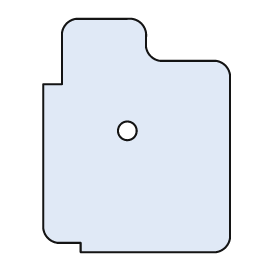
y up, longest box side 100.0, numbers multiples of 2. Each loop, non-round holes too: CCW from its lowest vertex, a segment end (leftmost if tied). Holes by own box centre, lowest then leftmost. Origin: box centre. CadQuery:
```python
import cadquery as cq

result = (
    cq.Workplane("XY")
    .moveTo(-24.0, -50.0)
    .lineTo(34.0, -50.0)
    .threePointArc((38.0, -48.0), (40.0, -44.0))
    .lineTo(40.0, 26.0)
    .threePointArc((38.0, 30.0), (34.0, 32.0))
    .lineTo(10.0, 32.0)
    .threePointArc((6.0, 34.0), (4.0, 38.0))
    .lineTo(4.0, 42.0)
    .threePointArc((2.0, 48.0), (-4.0, 50.0))
    .lineTo(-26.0, 50.0)
    .threePointArc((-30.0, 48.0), (-32.0, 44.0))
    .lineTo(-32.0, 22.0)
    .lineTo(-40.0, 22.0)
    .lineTo(-40.0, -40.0)
    .threePointArc((-38.0, -44.0), (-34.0, -46.0))
    .lineTo(-24.0, -46.0)
    .close()
    .moveTo(-4.0, 2.0)
    .circle(4.0)
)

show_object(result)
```